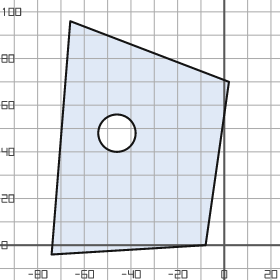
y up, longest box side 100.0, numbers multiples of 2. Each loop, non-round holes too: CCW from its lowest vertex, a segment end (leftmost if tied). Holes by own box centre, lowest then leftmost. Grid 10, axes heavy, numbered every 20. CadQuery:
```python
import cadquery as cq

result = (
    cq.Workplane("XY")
    .moveTo(-74.0, -4.0)
    .lineTo(-8.0, 0.0)
    .lineTo(2.0, 70.0)
    .lineTo(-66.0, 96.0)
    .close()
    .moveTo(-46.0, 48.0)
    .circle(8.0)
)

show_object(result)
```